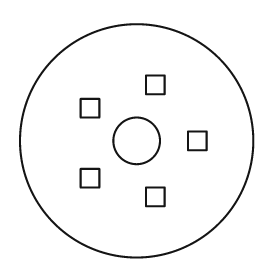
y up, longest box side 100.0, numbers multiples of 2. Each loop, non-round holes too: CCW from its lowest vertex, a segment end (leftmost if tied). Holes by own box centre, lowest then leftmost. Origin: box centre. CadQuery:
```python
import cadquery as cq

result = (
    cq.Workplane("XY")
    .moveTo(0.0, 0.0)
    .circle(50.0)
    .moveTo(4.0, -28.0)
    .lineTo(12.0, -28.0)
    .lineTo(12.0, -20.0)
    .lineTo(4.0, -20.0)
    .close()
    .moveTo(-24.0, -20.0)
    .lineTo(-16.0, -20.0)
    .lineTo(-16.0, -12.0)
    .lineTo(-24.0, -12.0)
    .close()
    .moveTo(0.0, 0.0)
    .circle(10.0)
    .moveTo(22.0, -4.0)
    .lineTo(30.0, -4.0)
    .lineTo(30.0, 4.0)
    .lineTo(22.0, 4.0)
    .close()
    .moveTo(-24.0, 10.0)
    .lineTo(-16.0, 10.0)
    .lineTo(-16.0, 18.0)
    .lineTo(-24.0, 18.0)
    .close()
    .moveTo(4.0, 20.0)
    .lineTo(12.0, 20.0)
    .lineTo(12.0, 28.0)
    .lineTo(4.0, 28.0)
    .close()
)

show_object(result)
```